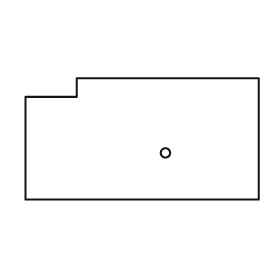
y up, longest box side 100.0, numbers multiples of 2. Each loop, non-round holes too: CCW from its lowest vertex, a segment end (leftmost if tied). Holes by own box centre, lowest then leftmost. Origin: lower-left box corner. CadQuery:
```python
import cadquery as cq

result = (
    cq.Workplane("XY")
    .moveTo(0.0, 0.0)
    .lineTo(100.0, 0.0)
    .lineTo(100.0, 52.0)
    .lineTo(22.0, 52.0)
    .lineTo(22.0, 44.0)
    .lineTo(0.0, 44.0)
    .close()
    .moveTo(60.0, 20.0)
    .circle(2.0)
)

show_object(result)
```